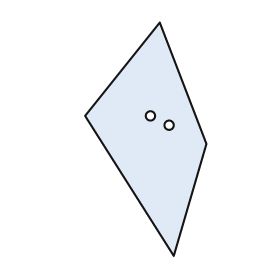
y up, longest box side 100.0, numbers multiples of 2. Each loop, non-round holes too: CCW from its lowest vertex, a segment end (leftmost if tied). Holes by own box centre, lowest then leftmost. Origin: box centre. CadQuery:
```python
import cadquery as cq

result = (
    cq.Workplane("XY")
    .moveTo(12.0, -50.0)
    .lineTo(26.0, -2.0)
    .lineTo(6.0, 50.0)
    .lineTo(-26.0, 10.0)
    .close()
    .moveTo(10.0, 6.0)
    .circle(2.0)
    .moveTo(2.0, 10.0)
    .circle(2.0)
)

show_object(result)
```